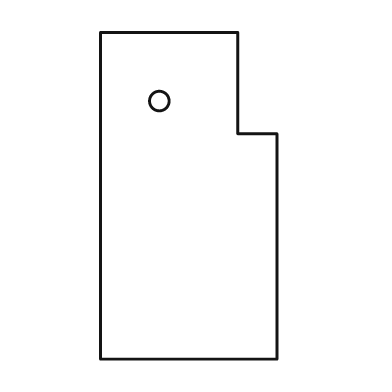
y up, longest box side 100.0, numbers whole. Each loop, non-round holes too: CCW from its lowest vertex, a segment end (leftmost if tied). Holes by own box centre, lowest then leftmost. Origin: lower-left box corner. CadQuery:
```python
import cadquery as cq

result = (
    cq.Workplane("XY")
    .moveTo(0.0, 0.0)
    .lineTo(54.0, 0.0)
    .lineTo(54.0, 69.0)
    .lineTo(42.0, 69.0)
    .lineTo(42.0, 100.0)
    .lineTo(0.0, 100.0)
    .close()
    .moveTo(18.0, 79.0)
    .circle(3.0)
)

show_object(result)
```